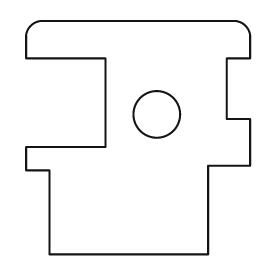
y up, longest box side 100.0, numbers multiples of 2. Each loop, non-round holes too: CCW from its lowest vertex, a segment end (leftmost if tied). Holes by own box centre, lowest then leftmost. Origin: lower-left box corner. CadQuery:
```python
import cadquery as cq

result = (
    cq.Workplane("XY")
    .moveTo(10.0, 0.0)
    .lineTo(78.0, 0.0)
    .lineTo(78.0, 38.0)
    .lineTo(96.0, 38.0)
    .lineTo(96.0, 58.0)
    .lineTo(86.0, 58.0)
    .lineTo(86.0, 84.0)
    .lineTo(96.0, 84.0)
    .lineTo(96.0, 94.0)
    .threePointArc((94.0, 98.0), (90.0, 100.0))
    .lineTo(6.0, 100.0)
    .threePointArc((2.0, 98.0), (0.0, 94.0))
    .lineTo(0.0, 84.0)
    .lineTo(34.0, 84.0)
    .lineTo(34.0, 46.0)
    .lineTo(0.0, 46.0)
    .lineTo(0.0, 36.0)
    .lineTo(10.0, 36.0)
    .close()
    .moveTo(56.0, 60.0)
    .circle(10.0)
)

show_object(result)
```